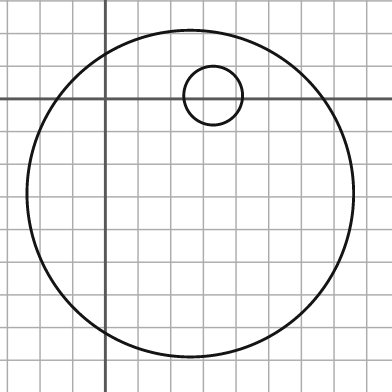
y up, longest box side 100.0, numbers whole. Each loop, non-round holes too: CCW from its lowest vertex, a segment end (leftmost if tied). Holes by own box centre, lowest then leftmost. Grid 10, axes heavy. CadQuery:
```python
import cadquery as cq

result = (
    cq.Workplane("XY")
    .moveTo(26.0, -29.0)
    .circle(50.0)
    .moveTo(33.0, 1.0)
    .circle(9.0)
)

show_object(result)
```